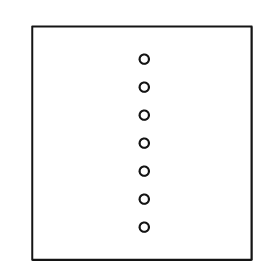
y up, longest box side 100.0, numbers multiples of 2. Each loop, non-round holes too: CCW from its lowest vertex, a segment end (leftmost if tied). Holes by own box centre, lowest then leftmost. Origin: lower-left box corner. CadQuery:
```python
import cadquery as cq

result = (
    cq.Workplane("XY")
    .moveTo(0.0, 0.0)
    .lineTo(94.0, 0.0)
    .lineTo(94.0, 100.0)
    .lineTo(0.0, 100.0)
    .close()
    .moveTo(48.0, 14.0)
    .circle(2.0)
    .moveTo(48.0, 26.0)
    .circle(2.0)
    .moveTo(48.0, 38.0)
    .circle(2.0)
    .moveTo(48.0, 50.0)
    .circle(2.0)
    .moveTo(48.0, 62.0)
    .circle(2.0)
    .moveTo(48.0, 74.0)
    .circle(2.0)
    .moveTo(48.0, 86.0)
    .circle(2.0)
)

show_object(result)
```